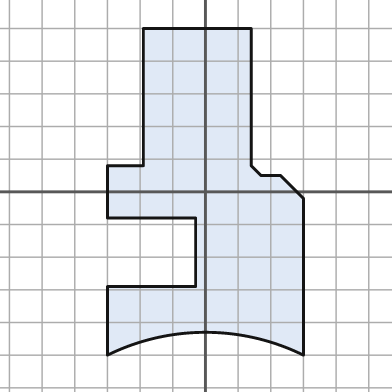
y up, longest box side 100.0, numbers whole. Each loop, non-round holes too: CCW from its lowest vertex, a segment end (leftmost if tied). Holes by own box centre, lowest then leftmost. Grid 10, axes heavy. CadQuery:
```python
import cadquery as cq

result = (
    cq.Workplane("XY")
    .moveTo(-30.0, -50.0)
    .threePointArc((0.0, -43.0), (30.0, -50.0))
    .lineTo(30.0, -2.0)
    .lineTo(23.0, 5.0)
    .lineTo(17.0, 5.0)
    .lineTo(14.0, 8.0)
    .lineTo(14.0, 50.0)
    .lineTo(-19.0, 50.0)
    .lineTo(-19.0, 8.0)
    .lineTo(-30.0, 8.0)
    .lineTo(-30.0, -8.0)
    .lineTo(-3.0, -8.0)
    .lineTo(-3.0, -29.0)
    .lineTo(-30.0, -29.0)
    .close()
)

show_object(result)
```